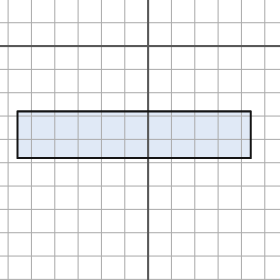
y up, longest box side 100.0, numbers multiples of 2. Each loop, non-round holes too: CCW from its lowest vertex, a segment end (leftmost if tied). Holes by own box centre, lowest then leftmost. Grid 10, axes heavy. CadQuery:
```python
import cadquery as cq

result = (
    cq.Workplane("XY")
    .moveTo(-56.0, -48.0)
    .lineTo(44.0, -48.0)
    .lineTo(44.0, -28.0)
    .lineTo(-56.0, -28.0)
    .close()
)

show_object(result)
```